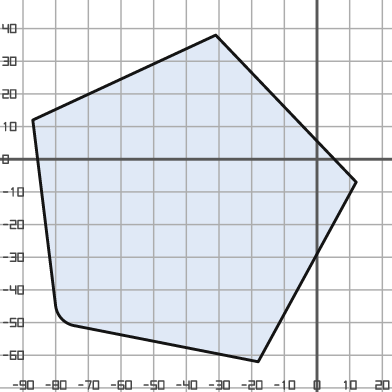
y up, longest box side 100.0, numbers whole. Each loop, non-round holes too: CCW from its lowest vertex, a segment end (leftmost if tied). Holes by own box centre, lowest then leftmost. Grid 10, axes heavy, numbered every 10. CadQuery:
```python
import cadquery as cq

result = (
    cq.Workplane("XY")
    .moveTo(-18.0, -62.0)
    .lineTo(12.0, -7.0)
    .lineTo(-31.0, 38.0)
    .lineTo(-87.0, 12.0)
    .lineTo(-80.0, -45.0)
    .threePointArc((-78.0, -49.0), (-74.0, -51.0))
    .close()
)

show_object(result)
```